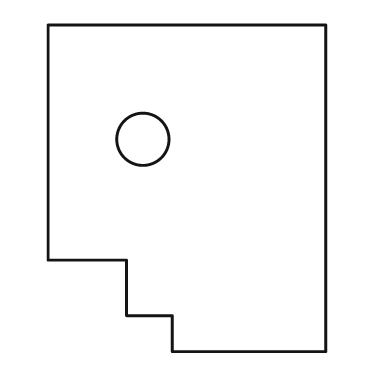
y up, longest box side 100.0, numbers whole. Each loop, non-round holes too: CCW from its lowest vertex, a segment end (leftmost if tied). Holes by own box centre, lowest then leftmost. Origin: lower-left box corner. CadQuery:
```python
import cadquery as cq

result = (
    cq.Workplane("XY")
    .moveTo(38.0, 0.0)
    .lineTo(85.0, 0.0)
    .lineTo(85.0, 100.0)
    .lineTo(0.0, 100.0)
    .lineTo(0.0, 28.0)
    .lineTo(24.0, 28.0)
    .lineTo(24.0, 11.0)
    .lineTo(38.0, 11.0)
    .close()
    .moveTo(29.0, 65.0)
    .circle(8.0)
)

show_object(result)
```